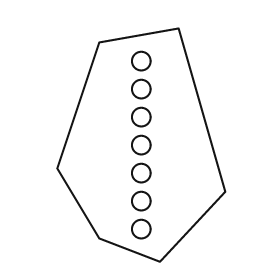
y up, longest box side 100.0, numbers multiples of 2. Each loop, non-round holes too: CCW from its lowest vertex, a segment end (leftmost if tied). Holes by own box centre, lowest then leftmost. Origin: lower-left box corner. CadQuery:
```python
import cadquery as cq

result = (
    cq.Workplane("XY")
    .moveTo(44.0, 0.0)
    .lineTo(72.0, 30.0)
    .lineTo(52.0, 100.0)
    .lineTo(18.0, 94.0)
    .lineTo(0.0, 40.0)
    .lineTo(18.0, 10.0)
    .close()
    .moveTo(36.0, 14.0)
    .circle(4.0)
    .moveTo(36.0, 26.0)
    .circle(4.0)
    .moveTo(36.0, 38.0)
    .circle(4.0)
    .moveTo(36.0, 50.0)
    .circle(4.0)
    .moveTo(36.0, 62.0)
    .circle(4.0)
    .moveTo(36.0, 74.0)
    .circle(4.0)
    .moveTo(36.0, 86.0)
    .circle(4.0)
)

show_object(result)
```